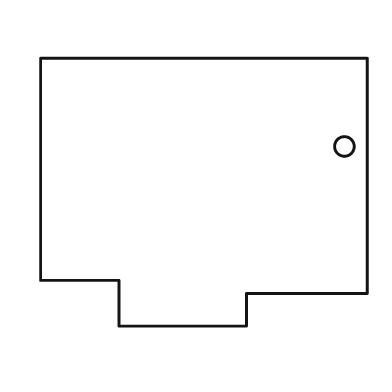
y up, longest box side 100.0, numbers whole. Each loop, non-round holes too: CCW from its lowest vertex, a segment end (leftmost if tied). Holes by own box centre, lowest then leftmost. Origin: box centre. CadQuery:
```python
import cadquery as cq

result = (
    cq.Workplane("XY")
    .moveTo(-26.0, -41.0)
    .lineTo(13.0, -41.0)
    .lineTo(13.0, -31.0)
    .lineTo(50.0, -31.0)
    .lineTo(50.0, 41.0)
    .lineTo(-50.0, 41.0)
    .lineTo(-50.0, -27.0)
    .lineTo(-26.0, -27.0)
    .close()
    .moveTo(43.0, 14.0)
    .circle(3.0)
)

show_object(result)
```